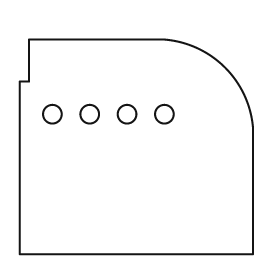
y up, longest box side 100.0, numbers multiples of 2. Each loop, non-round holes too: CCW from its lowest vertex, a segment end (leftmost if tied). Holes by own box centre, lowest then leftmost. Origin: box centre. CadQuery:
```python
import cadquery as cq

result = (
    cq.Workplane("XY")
    .moveTo(-50.0, -46.0)
    .lineTo(50.0, -46.0)
    .lineTo(50.0, 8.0)
    .threePointArc((38.0, 34.0), (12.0, 46.0))
    .lineTo(-46.0, 46.0)
    .lineTo(-46.0, 28.0)
    .lineTo(-50.0, 28.0)
    .close()
    .moveTo(-36.0, 14.0)
    .circle(4.0)
    .moveTo(-20.0, 14.0)
    .circle(4.0)
    .moveTo(-4.0, 14.0)
    .circle(4.0)
    .moveTo(12.0, 14.0)
    .circle(4.0)
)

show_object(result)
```